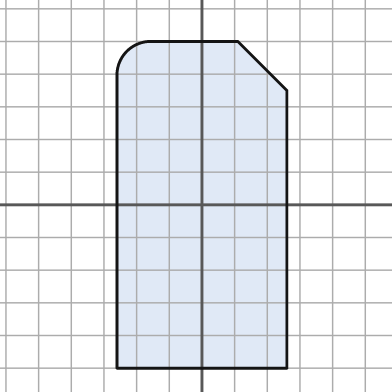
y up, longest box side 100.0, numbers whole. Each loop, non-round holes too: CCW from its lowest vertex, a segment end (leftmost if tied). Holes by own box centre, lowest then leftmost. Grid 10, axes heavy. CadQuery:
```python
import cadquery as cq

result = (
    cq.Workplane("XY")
    .moveTo(-26.0, -50.0)
    .lineTo(26.0, -50.0)
    .lineTo(26.0, 35.0)
    .lineTo(11.0, 50.0)
    .lineTo(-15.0, 50.0)
    .threePointArc((-23.0, 47.0), (-26.0, 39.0))
    .close()
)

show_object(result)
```